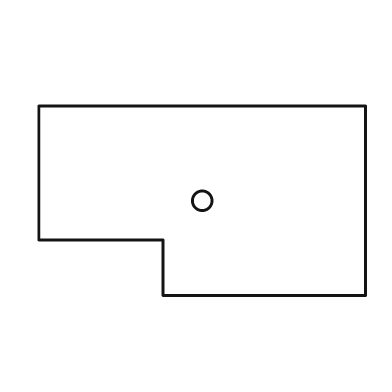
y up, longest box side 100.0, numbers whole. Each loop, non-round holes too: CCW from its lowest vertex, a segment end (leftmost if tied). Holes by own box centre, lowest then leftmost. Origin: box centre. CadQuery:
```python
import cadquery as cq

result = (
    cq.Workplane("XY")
    .moveTo(-12.0, -29.0)
    .lineTo(50.0, -29.0)
    .lineTo(50.0, 29.0)
    .lineTo(-50.0, 29.0)
    .lineTo(-50.0, -12.0)
    .lineTo(-12.0, -12.0)
    .close()
    .moveTo(0.0, 0.0)
    .circle(3.0)
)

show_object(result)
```